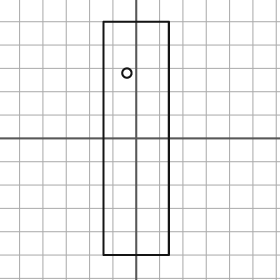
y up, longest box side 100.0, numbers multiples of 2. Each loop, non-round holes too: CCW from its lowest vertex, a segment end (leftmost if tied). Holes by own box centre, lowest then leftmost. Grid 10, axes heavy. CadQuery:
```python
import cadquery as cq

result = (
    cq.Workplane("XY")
    .moveTo(-14.0, -50.0)
    .lineTo(14.0, -50.0)
    .lineTo(14.0, 50.0)
    .lineTo(-14.0, 50.0)
    .close()
    .moveTo(-4.0, 28.0)
    .circle(2.0)
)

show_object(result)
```